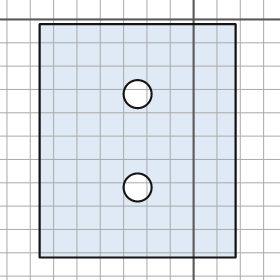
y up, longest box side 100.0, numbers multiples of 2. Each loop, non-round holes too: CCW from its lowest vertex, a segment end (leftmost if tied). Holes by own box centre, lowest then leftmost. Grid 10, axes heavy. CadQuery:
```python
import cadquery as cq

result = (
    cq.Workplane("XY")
    .moveTo(-66.0, -102.0)
    .lineTo(18.0, -102.0)
    .lineTo(18.0, -2.0)
    .lineTo(-66.0, -2.0)
    .close()
    .moveTo(-24.0, -72.0)
    .circle(6.0)
    .moveTo(-24.0, -32.0)
    .circle(6.0)
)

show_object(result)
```